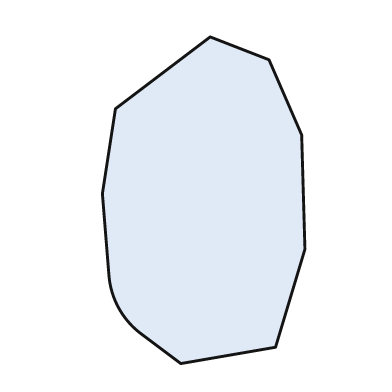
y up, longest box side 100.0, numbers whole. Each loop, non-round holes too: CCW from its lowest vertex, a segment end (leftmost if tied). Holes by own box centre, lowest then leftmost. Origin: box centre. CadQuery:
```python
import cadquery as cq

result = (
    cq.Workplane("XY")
    .moveTo(-7.0, -50.0)
    .lineTo(22.0, -45.0)
    .lineTo(31.0, -15.0)
    .lineTo(30.0, 20.0)
    .lineTo(20.0, 43.0)
    .lineTo(2.0, 50.0)
    .lineTo(-27.0, 28.0)
    .lineTo(-31.0, 2.0)
    .lineTo(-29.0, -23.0)
    .threePointArc((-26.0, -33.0), (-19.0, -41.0))
    .close()
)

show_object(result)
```